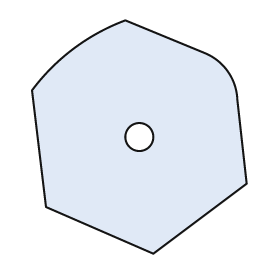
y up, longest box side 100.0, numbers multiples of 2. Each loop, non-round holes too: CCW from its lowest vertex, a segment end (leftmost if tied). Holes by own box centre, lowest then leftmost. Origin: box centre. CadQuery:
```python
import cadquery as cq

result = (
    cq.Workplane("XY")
    .moveTo(6.0, -50.0)
    .lineTo(46.0, -20.0)
    .lineTo(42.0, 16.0)
    .threePointArc((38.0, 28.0), (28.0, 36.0))
    .lineTo(-6.0, 50.0)
    .threePointArc((-28.0, 38.0), (-46.0, 20.0))
    .lineTo(-40.0, -30.0)
    .close()
    .moveTo(0.0, 0.0)
    .circle(6.0)
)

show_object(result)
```